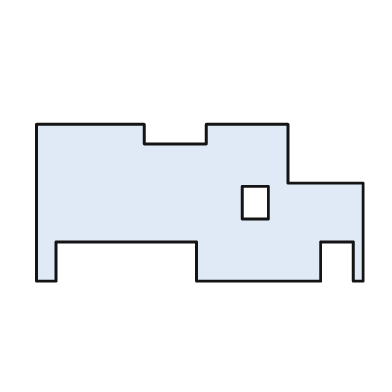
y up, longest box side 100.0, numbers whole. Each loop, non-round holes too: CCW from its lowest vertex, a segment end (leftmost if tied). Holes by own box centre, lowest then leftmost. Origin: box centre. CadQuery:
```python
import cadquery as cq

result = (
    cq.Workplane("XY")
    .moveTo(-50.0, -24.0)
    .lineTo(-44.0, -24.0)
    .lineTo(-44.0, -12.0)
    .lineTo(-1.0, -12.0)
    .lineTo(-1.0, -24.0)
    .lineTo(37.0, -24.0)
    .lineTo(37.0, -12.0)
    .lineTo(47.0, -12.0)
    .lineTo(47.0, -24.0)
    .lineTo(50.0, -24.0)
    .lineTo(50.0, 6.0)
    .lineTo(27.0, 6.0)
    .lineTo(27.0, 24.0)
    .lineTo(2.0, 24.0)
    .lineTo(2.0, 18.0)
    .lineTo(-17.0, 18.0)
    .lineTo(-17.0, 24.0)
    .lineTo(-50.0, 24.0)
    .close()
    .moveTo(13.0, -5.0)
    .lineTo(21.0, -5.0)
    .lineTo(21.0, 5.0)
    .lineTo(13.0, 5.0)
    .close()
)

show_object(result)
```